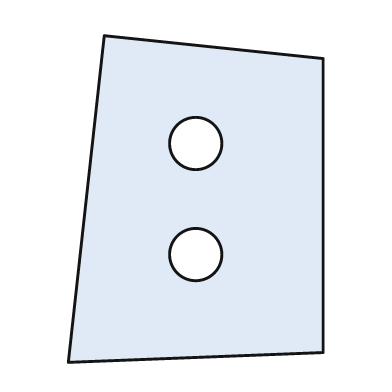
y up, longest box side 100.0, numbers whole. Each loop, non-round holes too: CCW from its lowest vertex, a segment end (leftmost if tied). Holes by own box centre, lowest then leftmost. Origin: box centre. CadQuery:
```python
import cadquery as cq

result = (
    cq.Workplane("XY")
    .moveTo(-39.0, -50.0)
    .lineTo(39.0, -47.0)
    .lineTo(39.0, 43.0)
    .lineTo(-28.0, 50.0)
    .close()
    .moveTo(0.0, -17.0)
    .circle(8.0)
    .moveTo(0.0, 17.0)
    .circle(8.0)
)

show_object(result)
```